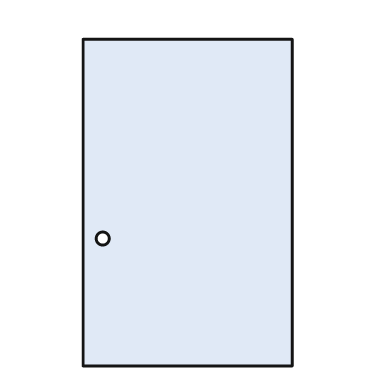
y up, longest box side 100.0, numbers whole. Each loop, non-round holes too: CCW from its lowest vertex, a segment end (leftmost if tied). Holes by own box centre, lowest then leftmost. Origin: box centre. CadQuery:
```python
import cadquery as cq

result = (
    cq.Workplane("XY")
    .moveTo(-32.0, -50.0)
    .lineTo(32.0, -50.0)
    .lineTo(32.0, 50.0)
    .lineTo(-32.0, 50.0)
    .close()
    .moveTo(-26.0, -11.0)
    .circle(2.0)
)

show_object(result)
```